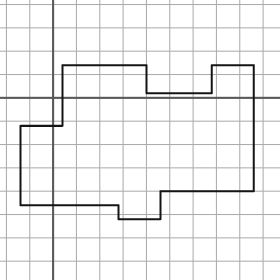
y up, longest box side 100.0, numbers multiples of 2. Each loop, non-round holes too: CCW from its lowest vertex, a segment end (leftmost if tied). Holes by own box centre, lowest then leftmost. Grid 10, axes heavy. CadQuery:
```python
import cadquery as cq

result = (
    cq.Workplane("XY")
    .moveTo(28.0, -52.0)
    .lineTo(46.0, -52.0)
    .lineTo(46.0, -40.0)
    .lineTo(86.0, -40.0)
    .lineTo(86.0, 14.0)
    .lineTo(68.0, 14.0)
    .lineTo(68.0, 2.0)
    .lineTo(40.0, 2.0)
    .lineTo(40.0, 14.0)
    .lineTo(4.0, 14.0)
    .lineTo(4.0, -12.0)
    .lineTo(-14.0, -12.0)
    .lineTo(-14.0, -46.0)
    .lineTo(28.0, -46.0)
    .close()
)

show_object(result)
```